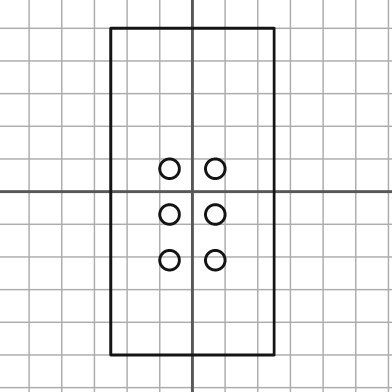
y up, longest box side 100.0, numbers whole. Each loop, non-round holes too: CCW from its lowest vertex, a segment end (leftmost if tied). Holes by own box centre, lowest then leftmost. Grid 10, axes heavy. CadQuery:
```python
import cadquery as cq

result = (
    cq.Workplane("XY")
    .moveTo(-25.0, -50.0)
    .lineTo(25.0, -50.0)
    .lineTo(25.0, 50.0)
    .lineTo(-25.0, 50.0)
    .close()
    .moveTo(-7.0, -21.0)
    .circle(3.0)
    .moveTo(7.0, -21.0)
    .circle(3.0)
    .moveTo(-7.0, -7.0)
    .circle(3.0)
    .moveTo(7.0, -7.0)
    .circle(3.0)
    .moveTo(-7.0, 7.0)
    .circle(3.0)
    .moveTo(7.0, 7.0)
    .circle(3.0)
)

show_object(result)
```